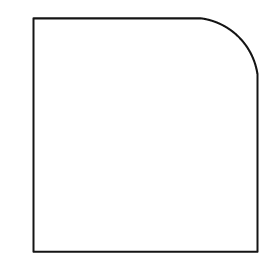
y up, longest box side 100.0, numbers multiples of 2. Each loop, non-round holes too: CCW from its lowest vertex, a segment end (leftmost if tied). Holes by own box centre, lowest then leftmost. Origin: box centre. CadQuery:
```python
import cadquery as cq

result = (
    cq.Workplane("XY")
    .moveTo(-48.0, -50.0)
    .lineTo(48.0, -50.0)
    .lineTo(48.0, 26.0)
    .threePointArc((40.0, 42.0), (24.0, 50.0))
    .lineTo(-48.0, 50.0)
    .close()
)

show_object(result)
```